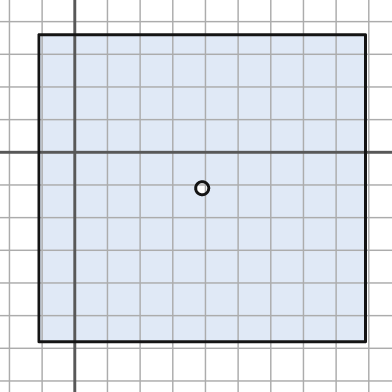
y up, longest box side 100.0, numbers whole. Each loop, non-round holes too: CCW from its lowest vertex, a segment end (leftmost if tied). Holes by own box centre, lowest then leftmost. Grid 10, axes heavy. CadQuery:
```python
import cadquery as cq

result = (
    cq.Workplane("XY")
    .moveTo(-11.0, -58.0)
    .lineTo(89.0, -58.0)
    .lineTo(89.0, 36.0)
    .lineTo(-11.0, 36.0)
    .close()
    .moveTo(39.0, -11.0)
    .circle(2.0)
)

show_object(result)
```